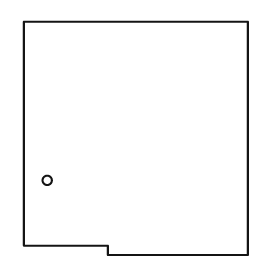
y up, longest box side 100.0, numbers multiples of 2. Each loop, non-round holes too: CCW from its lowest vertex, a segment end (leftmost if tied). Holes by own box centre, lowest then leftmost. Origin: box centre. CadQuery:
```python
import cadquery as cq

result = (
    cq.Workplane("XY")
    .moveTo(-12.0, -50.0)
    .lineTo(48.0, -50.0)
    .lineTo(48.0, 50.0)
    .lineTo(-48.0, 50.0)
    .lineTo(-48.0, -46.0)
    .lineTo(-12.0, -46.0)
    .close()
    .moveTo(-38.0, -18.0)
    .circle(2.0)
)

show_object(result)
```